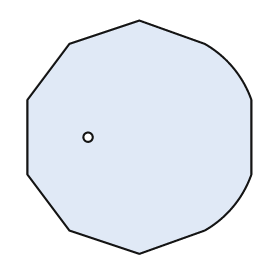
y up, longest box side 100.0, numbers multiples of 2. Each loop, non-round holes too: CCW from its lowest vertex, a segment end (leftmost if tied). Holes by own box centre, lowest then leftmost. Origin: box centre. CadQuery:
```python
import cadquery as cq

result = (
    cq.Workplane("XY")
    .moveTo(0.0, -50.0)
    .lineTo(28.0, -40.0)
    .threePointArc((40.0, -30.0), (48.0, -16.0))
    .lineTo(48.0, 16.0)
    .threePointArc((40.0, 30.0), (28.0, 40.0))
    .lineTo(0.0, 50.0)
    .lineTo(-30.0, 40.0)
    .lineTo(-48.0, 16.0)
    .lineTo(-48.0, -16.0)
    .lineTo(-30.0, -40.0)
    .close()
    .moveTo(-22.0, 0.0)
    .circle(2.0)
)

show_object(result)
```